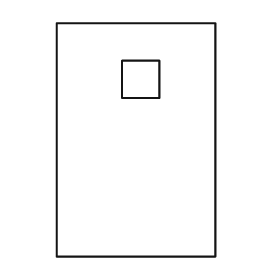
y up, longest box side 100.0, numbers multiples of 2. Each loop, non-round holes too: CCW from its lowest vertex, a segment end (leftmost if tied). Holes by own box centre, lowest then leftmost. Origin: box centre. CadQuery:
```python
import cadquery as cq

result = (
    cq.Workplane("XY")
    .moveTo(-34.0, -50.0)
    .lineTo(34.0, -50.0)
    .lineTo(34.0, 50.0)
    .lineTo(-34.0, 50.0)
    .close()
    .moveTo(-6.0, 18.0)
    .lineTo(10.0, 18.0)
    .lineTo(10.0, 34.0)
    .lineTo(-6.0, 34.0)
    .close()
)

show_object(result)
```